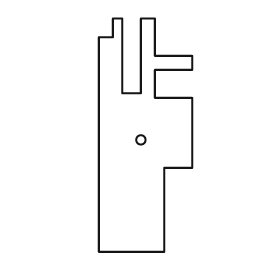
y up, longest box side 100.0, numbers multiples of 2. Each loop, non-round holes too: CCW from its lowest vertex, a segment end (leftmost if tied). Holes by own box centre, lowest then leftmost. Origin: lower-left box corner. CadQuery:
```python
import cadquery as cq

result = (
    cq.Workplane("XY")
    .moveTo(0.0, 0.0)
    .lineTo(28.0, 0.0)
    .lineTo(28.0, 36.0)
    .lineTo(40.0, 36.0)
    .lineTo(40.0, 66.0)
    .lineTo(24.0, 66.0)
    .lineTo(24.0, 78.0)
    .lineTo(40.0, 78.0)
    .lineTo(40.0, 84.0)
    .lineTo(24.0, 84.0)
    .lineTo(24.0, 100.0)
    .lineTo(18.0, 100.0)
    .lineTo(18.0, 68.0)
    .lineTo(10.0, 68.0)
    .lineTo(10.0, 100.0)
    .lineTo(6.0, 100.0)
    .lineTo(6.0, 92.0)
    .lineTo(0.0, 92.0)
    .close()
    .moveTo(18.0, 48.0)
    .circle(2.0)
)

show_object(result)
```